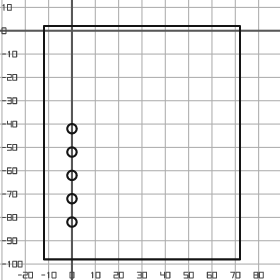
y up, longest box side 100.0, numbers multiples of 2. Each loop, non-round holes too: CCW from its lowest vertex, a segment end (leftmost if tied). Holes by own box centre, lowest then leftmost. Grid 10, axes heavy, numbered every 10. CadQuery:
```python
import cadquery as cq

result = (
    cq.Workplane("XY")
    .moveTo(-12.0, -98.0)
    .lineTo(72.0, -98.0)
    .lineTo(72.0, 2.0)
    .lineTo(-12.0, 2.0)
    .close()
    .moveTo(0.0, -82.0)
    .circle(2.0)
    .moveTo(0.0, -72.0)
    .circle(2.0)
    .moveTo(0.0, -62.0)
    .circle(2.0)
    .moveTo(0.0, -52.0)
    .circle(2.0)
    .moveTo(0.0, -42.0)
    .circle(2.0)
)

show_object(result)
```